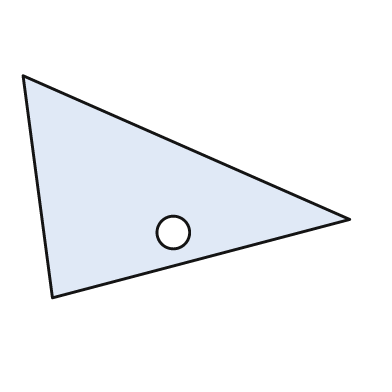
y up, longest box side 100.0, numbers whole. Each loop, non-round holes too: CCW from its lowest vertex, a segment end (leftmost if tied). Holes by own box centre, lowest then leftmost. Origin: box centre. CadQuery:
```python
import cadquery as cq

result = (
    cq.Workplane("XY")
    .moveTo(-41.0, -34.0)
    .lineTo(50.0, -10.0)
    .lineTo(-50.0, 34.0)
    .close()
    .moveTo(-4.0, -14.0)
    .circle(5.0)
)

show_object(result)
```